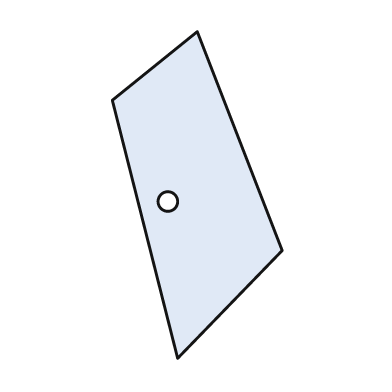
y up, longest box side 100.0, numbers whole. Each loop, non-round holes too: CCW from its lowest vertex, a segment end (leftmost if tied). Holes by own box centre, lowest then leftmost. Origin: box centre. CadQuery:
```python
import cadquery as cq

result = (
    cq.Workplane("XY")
    .moveTo(-6.0, -50.0)
    .lineTo(26.0, -17.0)
    .lineTo(0.0, 50.0)
    .lineTo(-26.0, 29.0)
    .close()
    .moveTo(-9.0, -2.0)
    .circle(3.0)
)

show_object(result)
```